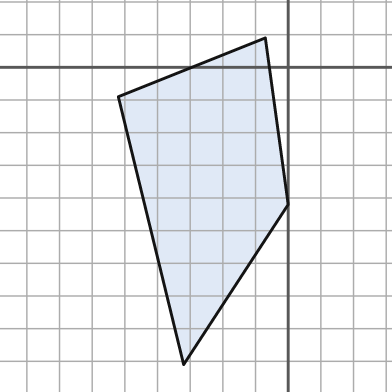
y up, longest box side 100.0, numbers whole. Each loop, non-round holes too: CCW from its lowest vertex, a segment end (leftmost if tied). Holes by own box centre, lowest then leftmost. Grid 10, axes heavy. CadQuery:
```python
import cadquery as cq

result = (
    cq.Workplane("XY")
    .moveTo(-32.0, -91.0)
    .lineTo(0.0, -42.0)
    .lineTo(-7.0, 9.0)
    .lineTo(-52.0, -9.0)
    .close()
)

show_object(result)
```